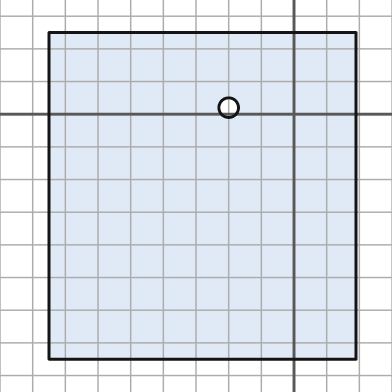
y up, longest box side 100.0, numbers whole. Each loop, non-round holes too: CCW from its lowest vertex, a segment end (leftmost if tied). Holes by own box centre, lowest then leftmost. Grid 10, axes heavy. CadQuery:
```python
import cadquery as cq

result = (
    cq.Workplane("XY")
    .moveTo(-75.0, -75.0)
    .lineTo(19.0, -75.0)
    .lineTo(19.0, 25.0)
    .lineTo(-75.0, 25.0)
    .close()
    .moveTo(-20.0, 2.0)
    .circle(3.0)
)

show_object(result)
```